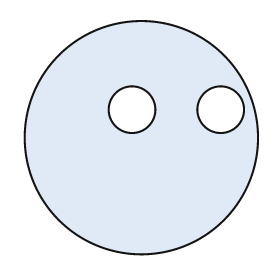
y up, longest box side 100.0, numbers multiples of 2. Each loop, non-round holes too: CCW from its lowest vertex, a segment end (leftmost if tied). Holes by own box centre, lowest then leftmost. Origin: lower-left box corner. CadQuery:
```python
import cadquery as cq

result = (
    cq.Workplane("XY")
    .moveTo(50.0, 50.0)
    .circle(50.0)
    .moveTo(46.0, 62.0)
    .circle(10.0)
    .moveTo(84.0, 62.0)
    .circle(10.0)
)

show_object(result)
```